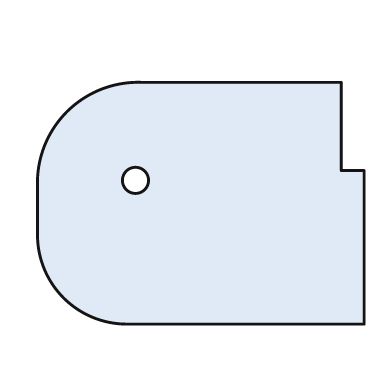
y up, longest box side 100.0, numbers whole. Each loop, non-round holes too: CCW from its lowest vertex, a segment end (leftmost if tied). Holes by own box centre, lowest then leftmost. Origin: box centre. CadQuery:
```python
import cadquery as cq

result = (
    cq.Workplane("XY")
    .moveTo(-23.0, -37.0)
    .lineTo(50.0, -37.0)
    .lineTo(50.0, 10.0)
    .lineTo(43.0, 10.0)
    .lineTo(43.0, 37.0)
    .lineTo(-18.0, 37.0)
    .threePointArc((-41.0, 28.0), (-50.0, 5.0))
    .lineTo(-50.0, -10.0)
    .threePointArc((-42.0, -29.0), (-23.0, -37.0))
    .close()
    .moveTo(-20.0, 7.0)
    .circle(4.0)
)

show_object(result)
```